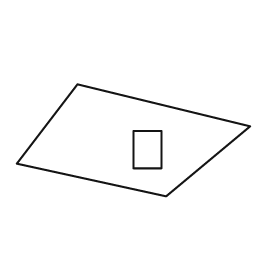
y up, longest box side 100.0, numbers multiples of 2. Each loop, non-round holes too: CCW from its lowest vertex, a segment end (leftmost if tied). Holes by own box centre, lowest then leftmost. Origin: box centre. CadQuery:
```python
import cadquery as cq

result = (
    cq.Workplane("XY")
    .moveTo(14.0, -24.0)
    .lineTo(50.0, 6.0)
    .lineTo(-24.0, 24.0)
    .lineTo(-50.0, -10.0)
    .close()
    .moveTo(0.0, -12.0)
    .lineTo(12.0, -12.0)
    .lineTo(12.0, 4.0)
    .lineTo(0.0, 4.0)
    .close()
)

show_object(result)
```